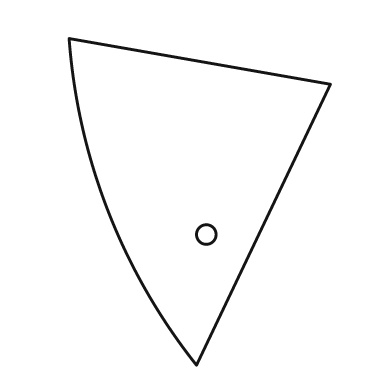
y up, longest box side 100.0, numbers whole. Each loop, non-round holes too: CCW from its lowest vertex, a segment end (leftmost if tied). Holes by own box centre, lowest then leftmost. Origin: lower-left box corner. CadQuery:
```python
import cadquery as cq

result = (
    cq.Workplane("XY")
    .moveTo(39.0, 0.0)
    .lineTo(80.0, 86.0)
    .lineTo(0.0, 100.0)
    .threePointArc((12.0, 47.0), (39.0, 0.0))
    .close()
    .moveTo(42.0, 40.0)
    .circle(3.0)
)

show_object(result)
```